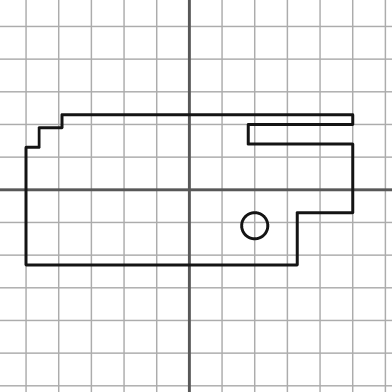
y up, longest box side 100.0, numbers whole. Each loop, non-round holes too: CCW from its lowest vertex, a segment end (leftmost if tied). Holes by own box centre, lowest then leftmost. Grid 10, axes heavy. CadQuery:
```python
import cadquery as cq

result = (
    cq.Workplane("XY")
    .moveTo(-50.0, -23.0)
    .lineTo(33.0, -23.0)
    .lineTo(33.0, -7.0)
    .lineTo(50.0, -7.0)
    .lineTo(50.0, 14.0)
    .lineTo(18.0, 14.0)
    .lineTo(18.0, 20.0)
    .lineTo(50.0, 20.0)
    .lineTo(50.0, 23.0)
    .lineTo(-39.0, 23.0)
    .lineTo(-39.0, 19.0)
    .lineTo(-46.0, 19.0)
    .lineTo(-46.0, 13.0)
    .lineTo(-50.0, 13.0)
    .close()
    .moveTo(20.0, -11.0)
    .circle(4.0)
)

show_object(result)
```